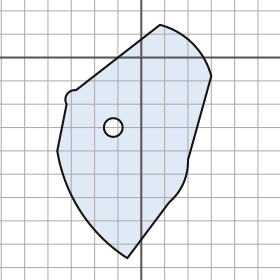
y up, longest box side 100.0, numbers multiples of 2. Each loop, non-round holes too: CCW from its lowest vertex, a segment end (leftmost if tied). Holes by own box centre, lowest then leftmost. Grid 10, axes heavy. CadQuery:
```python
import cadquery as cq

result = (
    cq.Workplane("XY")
    .moveTo(-6.0, -86.0)
    .lineTo(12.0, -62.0)
    .threePointArc((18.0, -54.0), (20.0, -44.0))
    .lineTo(30.0, -8.0)
    .threePointArc((22.0, 6.0), (8.0, 14.0))
    .lineTo(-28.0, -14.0)
    .threePointArc((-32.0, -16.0), (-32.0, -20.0))
    .lineTo(-36.0, -40.0)
    .threePointArc((-26.0, -66.0), (-6.0, -86.0))
    .close()
    .moveTo(-12.0, -30.0)
    .circle(4.0)
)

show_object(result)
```